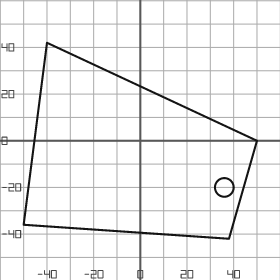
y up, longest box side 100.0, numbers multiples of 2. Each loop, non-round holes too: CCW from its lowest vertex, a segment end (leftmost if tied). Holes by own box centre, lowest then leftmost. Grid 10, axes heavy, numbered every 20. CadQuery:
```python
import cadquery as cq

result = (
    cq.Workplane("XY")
    .moveTo(38.0, -42.0)
    .lineTo(50.0, 0.0)
    .lineTo(-40.0, 42.0)
    .lineTo(-50.0, -36.0)
    .close()
    .moveTo(36.0, -20.0)
    .circle(4.0)
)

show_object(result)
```